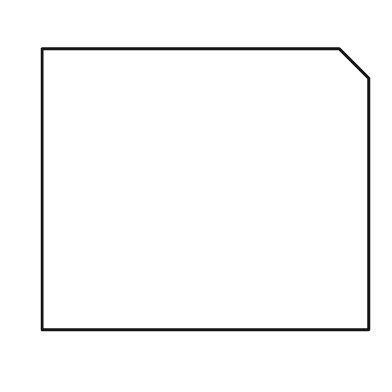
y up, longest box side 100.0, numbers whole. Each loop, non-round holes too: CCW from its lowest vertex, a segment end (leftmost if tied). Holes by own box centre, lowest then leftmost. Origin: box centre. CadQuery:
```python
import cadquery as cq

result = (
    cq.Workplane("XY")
    .moveTo(-50.0, -43.0)
    .lineTo(50.0, -43.0)
    .lineTo(50.0, 34.0)
    .lineTo(41.0, 43.0)
    .lineTo(-50.0, 43.0)
    .close()
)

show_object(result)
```